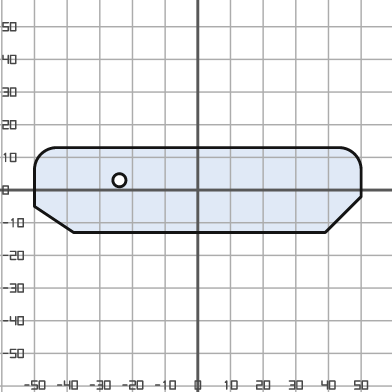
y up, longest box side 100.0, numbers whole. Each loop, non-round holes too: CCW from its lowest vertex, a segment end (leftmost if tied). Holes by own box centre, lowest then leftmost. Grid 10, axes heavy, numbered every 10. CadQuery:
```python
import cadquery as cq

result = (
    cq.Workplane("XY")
    .moveTo(-38.0, -13.0)
    .lineTo(39.0, -13.0)
    .lineTo(50.0, -2.0)
    .lineTo(50.0, 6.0)
    .threePointArc((48.0, 11.0), (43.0, 13.0))
    .lineTo(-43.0, 13.0)
    .threePointArc((-48.0, 11.0), (-50.0, 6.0))
    .lineTo(-50.0, -5.0)
    .close()
    .moveTo(-24.0, 3.0)
    .circle(2.0)
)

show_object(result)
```